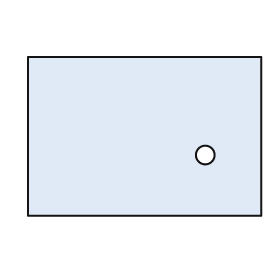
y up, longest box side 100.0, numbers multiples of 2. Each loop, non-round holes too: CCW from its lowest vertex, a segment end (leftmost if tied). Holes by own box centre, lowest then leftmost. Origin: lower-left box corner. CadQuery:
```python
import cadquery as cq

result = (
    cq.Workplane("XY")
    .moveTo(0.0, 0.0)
    .lineTo(100.0, 0.0)
    .lineTo(100.0, 68.0)
    .lineTo(0.0, 68.0)
    .close()
    .moveTo(76.0, 26.0)
    .circle(4.0)
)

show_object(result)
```